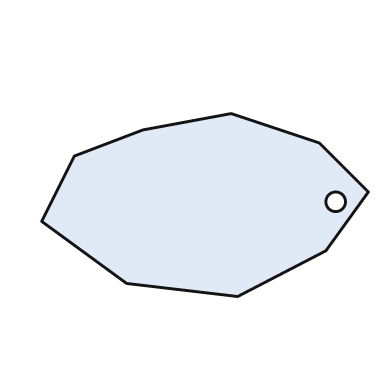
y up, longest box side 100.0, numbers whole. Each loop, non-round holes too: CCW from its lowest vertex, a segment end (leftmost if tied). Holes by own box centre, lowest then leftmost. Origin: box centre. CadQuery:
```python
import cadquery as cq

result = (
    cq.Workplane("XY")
    .moveTo(10.0, -28.0)
    .lineTo(37.0, -14.0)
    .lineTo(50.0, 4.0)
    .lineTo(35.0, 19.0)
    .lineTo(8.0, 28.0)
    .lineTo(-19.0, 23.0)
    .lineTo(-40.0, 15.0)
    .lineTo(-50.0, -5.0)
    .lineTo(-24.0, -24.0)
    .close()
    .moveTo(40.0, 1.0)
    .circle(3.0)
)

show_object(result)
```